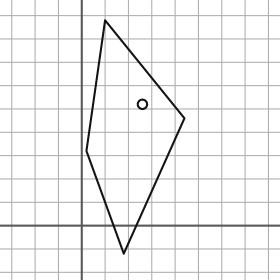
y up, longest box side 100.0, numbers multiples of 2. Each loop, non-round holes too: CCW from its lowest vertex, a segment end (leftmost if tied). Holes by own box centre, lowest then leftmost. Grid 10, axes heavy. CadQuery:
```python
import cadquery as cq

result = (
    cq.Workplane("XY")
    .moveTo(18.0, -12.0)
    .lineTo(44.0, 46.0)
    .lineTo(10.0, 88.0)
    .lineTo(2.0, 32.0)
    .close()
    .moveTo(26.0, 52.0)
    .circle(2.0)
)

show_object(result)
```